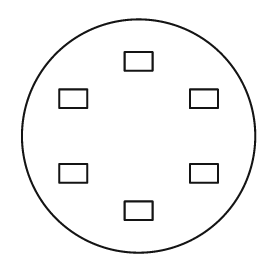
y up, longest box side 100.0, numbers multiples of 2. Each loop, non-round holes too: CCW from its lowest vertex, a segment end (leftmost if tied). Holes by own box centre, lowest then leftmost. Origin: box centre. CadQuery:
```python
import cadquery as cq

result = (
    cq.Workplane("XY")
    .moveTo(0.0, 0.0)
    .circle(50.0)
    .moveTo(-6.0, -36.0)
    .lineTo(6.0, -36.0)
    .lineTo(6.0, -28.0)
    .lineTo(-6.0, -28.0)
    .close()
    .moveTo(-34.0, -20.0)
    .lineTo(-22.0, -20.0)
    .lineTo(-22.0, -12.0)
    .lineTo(-34.0, -12.0)
    .close()
    .moveTo(22.0, -20.0)
    .lineTo(34.0, -20.0)
    .lineTo(34.0, -12.0)
    .lineTo(22.0, -12.0)
    .close()
    .moveTo(-34.0, 12.0)
    .lineTo(-22.0, 12.0)
    .lineTo(-22.0, 20.0)
    .lineTo(-34.0, 20.0)
    .close()
    .moveTo(22.0, 12.0)
    .lineTo(34.0, 12.0)
    .lineTo(34.0, 20.0)
    .lineTo(22.0, 20.0)
    .close()
    .moveTo(-6.0, 28.0)
    .lineTo(6.0, 28.0)
    .lineTo(6.0, 36.0)
    .lineTo(-6.0, 36.0)
    .close()
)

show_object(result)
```